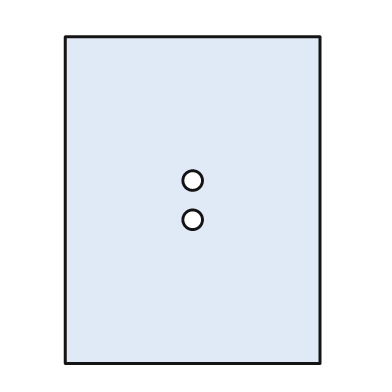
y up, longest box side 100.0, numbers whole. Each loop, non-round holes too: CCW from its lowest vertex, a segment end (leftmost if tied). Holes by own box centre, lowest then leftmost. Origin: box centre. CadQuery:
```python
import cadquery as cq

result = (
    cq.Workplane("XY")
    .moveTo(-39.0, -50.0)
    .lineTo(39.0, -50.0)
    .lineTo(39.0, 50.0)
    .lineTo(-39.0, 50.0)
    .close()
    .moveTo(0.0, -6.0)
    .circle(3.0)
    .moveTo(0.0, 6.0)
    .circle(3.0)
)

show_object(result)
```